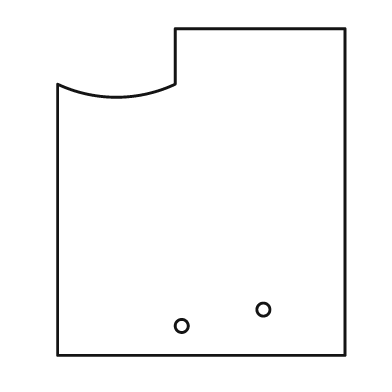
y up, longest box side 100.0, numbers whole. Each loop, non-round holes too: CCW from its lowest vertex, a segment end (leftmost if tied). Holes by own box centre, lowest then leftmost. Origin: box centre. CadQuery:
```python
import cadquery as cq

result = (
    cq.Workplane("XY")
    .moveTo(-44.0, -50.0)
    .lineTo(44.0, -50.0)
    .lineTo(44.0, 50.0)
    .lineTo(-8.0, 50.0)
    .lineTo(-8.0, 33.0)
    .threePointArc((-26.0, 29.0), (-44.0, 33.0))
    .close()
    .moveTo(-6.0, -41.0)
    .circle(2.0)
    .moveTo(19.0, -36.0)
    .circle(2.0)
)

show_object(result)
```